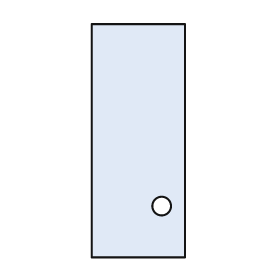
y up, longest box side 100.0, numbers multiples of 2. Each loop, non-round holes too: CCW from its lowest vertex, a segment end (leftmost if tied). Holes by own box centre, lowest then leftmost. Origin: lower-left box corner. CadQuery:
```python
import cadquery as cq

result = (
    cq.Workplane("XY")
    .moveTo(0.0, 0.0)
    .lineTo(40.0, 0.0)
    .lineTo(40.0, 100.0)
    .lineTo(0.0, 100.0)
    .close()
    .moveTo(30.0, 22.0)
    .circle(4.0)
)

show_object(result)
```